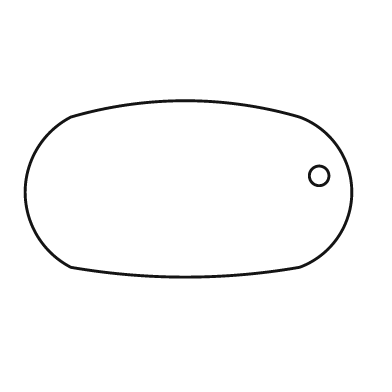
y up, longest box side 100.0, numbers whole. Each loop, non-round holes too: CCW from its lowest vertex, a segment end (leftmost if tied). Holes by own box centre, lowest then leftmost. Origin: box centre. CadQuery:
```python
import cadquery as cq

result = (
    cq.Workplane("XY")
    .moveTo(-36.0, -24.0)
    .threePointArc((-1.0, -27.0), (34.0, -24.0))
    .threePointArc((50.0, -1.0), (34.0, 22.0))
    .threePointArc((-1.0, 27.0), (-36.0, 22.0))
    .threePointArc((-50.0, -1.0), (-36.0, -24.0))
    .close()
    .moveTo(40.0, 4.0)
    .circle(3.0)
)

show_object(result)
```